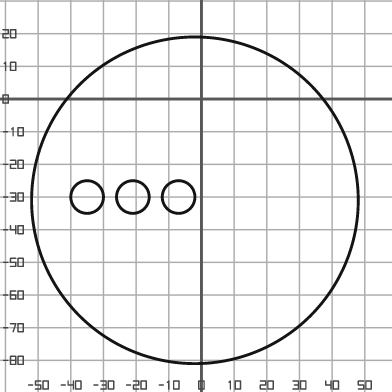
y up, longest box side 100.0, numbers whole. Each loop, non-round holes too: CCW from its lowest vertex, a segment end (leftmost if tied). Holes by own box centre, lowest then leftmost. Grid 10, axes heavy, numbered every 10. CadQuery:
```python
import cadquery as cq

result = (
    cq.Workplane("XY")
    .moveTo(-2.0, -31.0)
    .circle(50.0)
    .moveTo(-35.0, -30.0)
    .circle(5.0)
    .moveTo(-21.0, -30.0)
    .circle(5.0)
    .moveTo(-7.0, -30.0)
    .circle(5.0)
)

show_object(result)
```